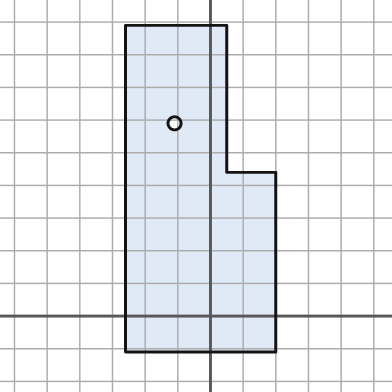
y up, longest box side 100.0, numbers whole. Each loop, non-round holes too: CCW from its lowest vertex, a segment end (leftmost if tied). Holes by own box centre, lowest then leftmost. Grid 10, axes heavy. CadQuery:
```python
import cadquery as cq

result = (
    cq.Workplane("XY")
    .moveTo(-26.0, -11.0)
    .lineTo(20.0, -11.0)
    .lineTo(20.0, 44.0)
    .lineTo(5.0, 44.0)
    .lineTo(5.0, 89.0)
    .lineTo(-26.0, 89.0)
    .close()
    .moveTo(-11.0, 59.0)
    .circle(2.0)
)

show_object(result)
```